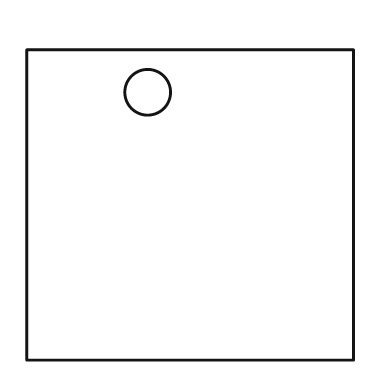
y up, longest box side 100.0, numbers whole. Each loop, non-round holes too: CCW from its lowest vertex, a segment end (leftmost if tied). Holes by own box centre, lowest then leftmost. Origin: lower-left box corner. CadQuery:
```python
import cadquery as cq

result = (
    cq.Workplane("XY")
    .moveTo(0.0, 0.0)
    .lineTo(100.0, 0.0)
    .lineTo(100.0, 95.0)
    .lineTo(0.0, 95.0)
    .close()
    .moveTo(37.0, 82.0)
    .circle(7.0)
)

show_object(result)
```